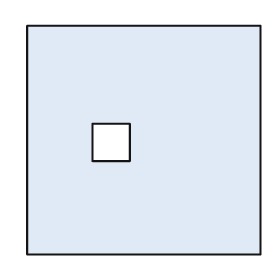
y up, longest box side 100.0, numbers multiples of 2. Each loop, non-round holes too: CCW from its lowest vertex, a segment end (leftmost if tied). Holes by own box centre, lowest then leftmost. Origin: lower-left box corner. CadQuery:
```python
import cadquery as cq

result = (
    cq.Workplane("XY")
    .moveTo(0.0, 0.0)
    .lineTo(100.0, 0.0)
    .lineTo(100.0, 98.0)
    .lineTo(0.0, 98.0)
    .close()
    .moveTo(28.0, 40.0)
    .lineTo(44.0, 40.0)
    .lineTo(44.0, 56.0)
    .lineTo(28.0, 56.0)
    .close()
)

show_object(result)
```